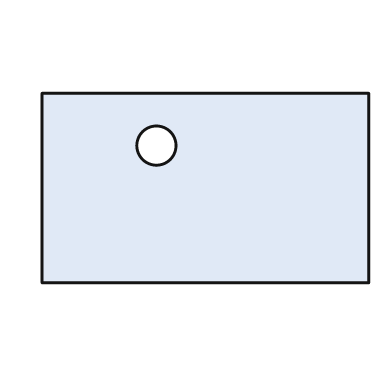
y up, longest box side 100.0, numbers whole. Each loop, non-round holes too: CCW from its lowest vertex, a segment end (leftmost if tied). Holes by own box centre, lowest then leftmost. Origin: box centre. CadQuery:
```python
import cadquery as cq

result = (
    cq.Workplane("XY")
    .moveTo(-50.0, -29.0)
    .lineTo(50.0, -29.0)
    .lineTo(50.0, 29.0)
    .lineTo(-50.0, 29.0)
    .close()
    .moveTo(-15.0, 13.0)
    .circle(6.0)
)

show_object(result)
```